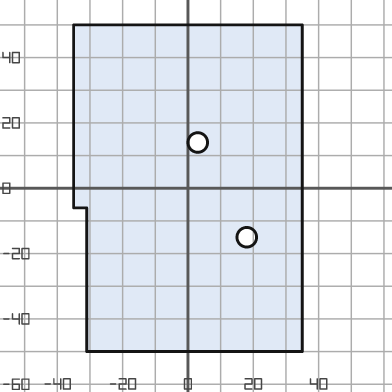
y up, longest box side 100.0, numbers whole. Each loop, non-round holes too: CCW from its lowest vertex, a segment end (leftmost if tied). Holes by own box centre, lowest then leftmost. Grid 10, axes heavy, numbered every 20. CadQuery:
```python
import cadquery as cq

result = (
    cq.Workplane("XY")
    .moveTo(-31.0, -50.0)
    .lineTo(35.0, -50.0)
    .lineTo(35.0, 50.0)
    .lineTo(-35.0, 50.0)
    .lineTo(-35.0, -6.0)
    .lineTo(-31.0, -6.0)
    .close()
    .moveTo(18.0, -15.0)
    .circle(3.0)
    .moveTo(3.0, 14.0)
    .circle(3.0)
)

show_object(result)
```